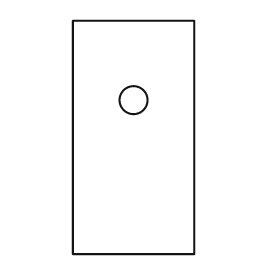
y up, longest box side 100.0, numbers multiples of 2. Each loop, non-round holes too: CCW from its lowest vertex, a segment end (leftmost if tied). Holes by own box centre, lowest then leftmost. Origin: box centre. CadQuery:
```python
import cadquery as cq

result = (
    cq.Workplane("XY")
    .moveTo(-26.0, -50.0)
    .lineTo(26.0, -50.0)
    .lineTo(26.0, 50.0)
    .lineTo(-26.0, 50.0)
    .close()
    .moveTo(0.0, 16.0)
    .circle(6.0)
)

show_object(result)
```